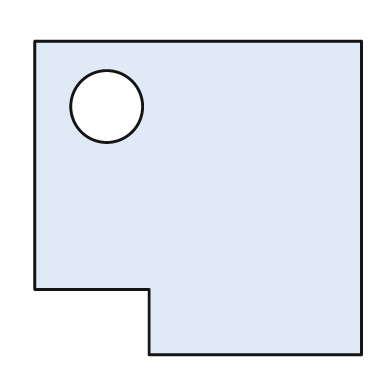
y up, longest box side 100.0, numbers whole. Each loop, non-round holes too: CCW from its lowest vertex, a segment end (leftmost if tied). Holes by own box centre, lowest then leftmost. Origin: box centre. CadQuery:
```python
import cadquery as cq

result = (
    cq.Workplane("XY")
    .moveTo(-15.0, -48.0)
    .lineTo(50.0, -48.0)
    .lineTo(50.0, 48.0)
    .lineTo(-50.0, 48.0)
    .lineTo(-50.0, -28.0)
    .lineTo(-15.0, -28.0)
    .close()
    .moveTo(-28.0, 28.0)
    .circle(11.0)
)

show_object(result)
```